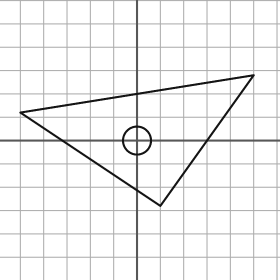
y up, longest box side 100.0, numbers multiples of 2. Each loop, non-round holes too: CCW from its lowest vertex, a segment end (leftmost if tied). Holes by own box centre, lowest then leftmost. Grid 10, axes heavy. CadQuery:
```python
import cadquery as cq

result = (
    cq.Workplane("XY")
    .moveTo(10.0, -28.0)
    .lineTo(50.0, 28.0)
    .lineTo(-50.0, 12.0)
    .close()
    .moveTo(0.0, 0.0)
    .circle(6.0)
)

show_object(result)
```